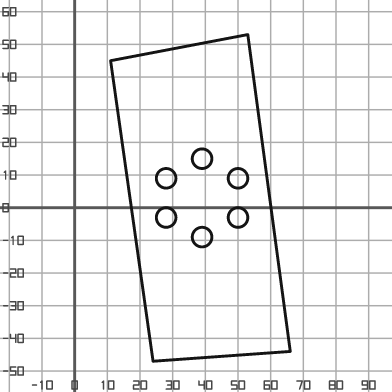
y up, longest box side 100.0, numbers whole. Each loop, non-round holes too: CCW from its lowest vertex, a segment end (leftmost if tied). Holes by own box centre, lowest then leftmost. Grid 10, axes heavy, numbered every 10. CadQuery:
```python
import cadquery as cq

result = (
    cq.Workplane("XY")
    .moveTo(24.0, -47.0)
    .lineTo(66.0, -44.0)
    .lineTo(53.0, 53.0)
    .lineTo(11.0, 45.0)
    .close()
    .moveTo(39.0, -9.0)
    .circle(3.0)
    .moveTo(28.0, -3.0)
    .circle(3.0)
    .moveTo(50.0, -3.0)
    .circle(3.0)
    .moveTo(28.0, 9.0)
    .circle(3.0)
    .moveTo(50.0, 9.0)
    .circle(3.0)
    .moveTo(39.0, 15.0)
    .circle(3.0)
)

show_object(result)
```